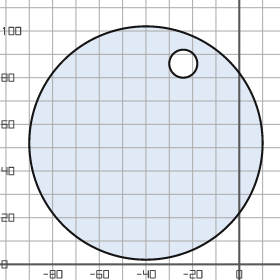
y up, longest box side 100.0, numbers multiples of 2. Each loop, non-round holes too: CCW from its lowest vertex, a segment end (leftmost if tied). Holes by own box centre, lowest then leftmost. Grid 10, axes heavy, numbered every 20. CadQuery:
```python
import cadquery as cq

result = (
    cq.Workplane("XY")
    .moveTo(-40.0, 52.0)
    .circle(50.0)
    .moveTo(-24.0, 86.0)
    .circle(6.0)
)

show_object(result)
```